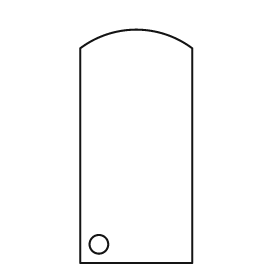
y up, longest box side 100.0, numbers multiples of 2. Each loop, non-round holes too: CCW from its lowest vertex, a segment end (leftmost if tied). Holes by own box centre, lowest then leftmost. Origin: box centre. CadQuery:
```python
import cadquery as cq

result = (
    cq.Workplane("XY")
    .moveTo(-24.0, -50.0)
    .lineTo(24.0, -50.0)
    .lineTo(24.0, 42.0)
    .threePointArc((0.0, 50.0), (-24.0, 42.0))
    .close()
    .moveTo(-16.0, -42.0)
    .circle(4.0)
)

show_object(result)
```